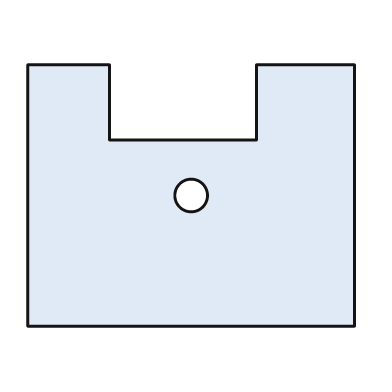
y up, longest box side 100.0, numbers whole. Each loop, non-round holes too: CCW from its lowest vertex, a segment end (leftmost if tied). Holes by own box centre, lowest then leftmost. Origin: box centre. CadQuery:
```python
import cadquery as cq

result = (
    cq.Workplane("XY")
    .moveTo(-50.0, -40.0)
    .lineTo(50.0, -40.0)
    .lineTo(50.0, 40.0)
    .lineTo(20.0, 40.0)
    .lineTo(20.0, 17.0)
    .lineTo(-25.0, 17.0)
    .lineTo(-25.0, 40.0)
    .lineTo(-50.0, 40.0)
    .close()
    .moveTo(0.0, 0.0)
    .circle(5.0)
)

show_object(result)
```